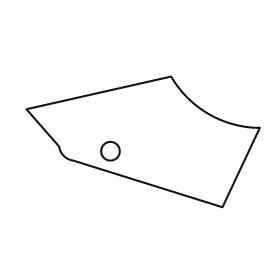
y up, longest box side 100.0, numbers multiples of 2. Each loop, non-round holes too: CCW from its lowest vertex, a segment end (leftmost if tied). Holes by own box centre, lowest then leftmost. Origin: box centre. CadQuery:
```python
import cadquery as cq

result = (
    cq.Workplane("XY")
    .moveTo(34.0, -28.0)
    .lineTo(50.0, 6.0)
    .threePointArc((28.0, 12.0), (12.0, 28.0))
    .lineTo(-50.0, 14.0)
    .lineTo(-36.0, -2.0)
    .threePointArc((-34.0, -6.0), (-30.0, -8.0))
    .close()
    .moveTo(-14.0, -4.0)
    .circle(4.0)
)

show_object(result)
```